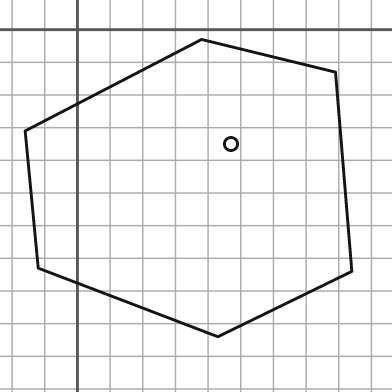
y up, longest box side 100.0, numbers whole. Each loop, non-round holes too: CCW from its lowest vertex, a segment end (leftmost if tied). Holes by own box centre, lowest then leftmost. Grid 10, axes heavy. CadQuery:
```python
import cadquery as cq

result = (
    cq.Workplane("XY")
    .moveTo(43.0, -94.0)
    .lineTo(84.0, -74.0)
    .lineTo(79.0, -13.0)
    .lineTo(38.0, -3.0)
    .lineTo(-16.0, -31.0)
    .lineTo(-12.0, -73.0)
    .close()
    .moveTo(47.0, -35.0)
    .circle(2.0)
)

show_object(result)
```